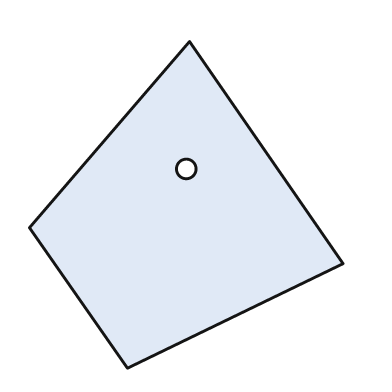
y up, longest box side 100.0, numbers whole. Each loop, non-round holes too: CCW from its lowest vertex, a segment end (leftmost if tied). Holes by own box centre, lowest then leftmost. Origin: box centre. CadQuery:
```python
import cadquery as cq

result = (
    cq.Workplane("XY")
    .moveTo(-18.0, -50.0)
    .lineTo(48.0, -18.0)
    .lineTo(1.0, 50.0)
    .lineTo(-48.0, -7.0)
    .close()
    .moveTo(0.0, 11.0)
    .circle(3.0)
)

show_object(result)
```